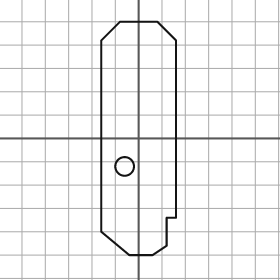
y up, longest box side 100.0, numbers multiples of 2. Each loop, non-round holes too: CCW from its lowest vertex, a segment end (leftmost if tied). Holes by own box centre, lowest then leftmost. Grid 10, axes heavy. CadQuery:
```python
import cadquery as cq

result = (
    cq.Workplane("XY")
    .moveTo(-4.0, -50.0)
    .lineTo(6.0, -50.0)
    .lineTo(12.0, -46.0)
    .lineTo(12.0, -34.0)
    .lineTo(16.0, -34.0)
    .lineTo(16.0, 42.0)
    .lineTo(8.0, 50.0)
    .lineTo(-8.0, 50.0)
    .lineTo(-16.0, 42.0)
    .lineTo(-16.0, -40.0)
    .close()
    .moveTo(-6.0, -12.0)
    .circle(4.0)
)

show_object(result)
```